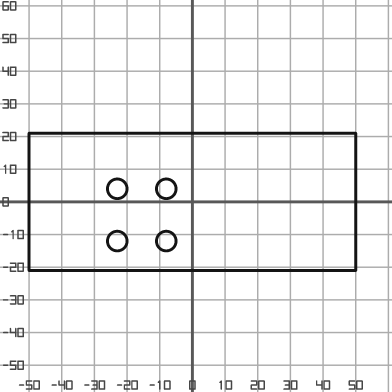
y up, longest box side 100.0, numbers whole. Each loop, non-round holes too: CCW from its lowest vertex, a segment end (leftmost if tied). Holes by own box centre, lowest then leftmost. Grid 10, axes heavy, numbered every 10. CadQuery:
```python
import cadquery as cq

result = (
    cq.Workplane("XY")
    .moveTo(-50.0, -21.0)
    .lineTo(50.0, -21.0)
    .lineTo(50.0, 21.0)
    .lineTo(-50.0, 21.0)
    .close()
    .moveTo(-23.0, -12.0)
    .circle(3.0)
    .moveTo(-8.0, -12.0)
    .circle(3.0)
    .moveTo(-23.0, 4.0)
    .circle(3.0)
    .moveTo(-8.0, 4.0)
    .circle(3.0)
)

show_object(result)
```